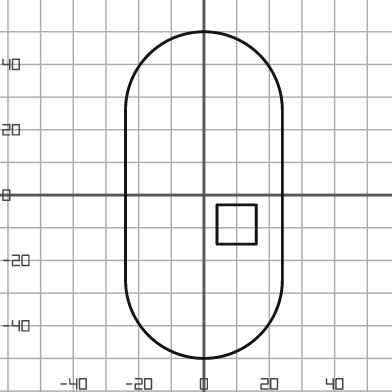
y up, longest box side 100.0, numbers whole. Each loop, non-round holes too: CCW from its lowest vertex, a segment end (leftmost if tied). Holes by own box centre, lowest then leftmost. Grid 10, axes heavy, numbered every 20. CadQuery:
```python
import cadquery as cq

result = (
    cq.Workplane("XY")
    .moveTo(-24.0, -26.0)
    .threePointArc((0.0, -50.0), (24.0, -26.0))
    .lineTo(24.0, 26.0)
    .threePointArc((0.0, 50.0), (-24.0, 26.0))
    .close()
    .moveTo(4.0, -15.0)
    .lineTo(16.0, -15.0)
    .lineTo(16.0, -3.0)
    .lineTo(4.0, -3.0)
    .close()
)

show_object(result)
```